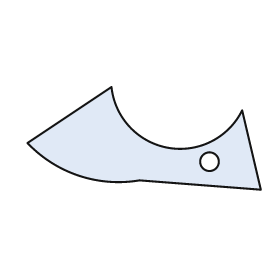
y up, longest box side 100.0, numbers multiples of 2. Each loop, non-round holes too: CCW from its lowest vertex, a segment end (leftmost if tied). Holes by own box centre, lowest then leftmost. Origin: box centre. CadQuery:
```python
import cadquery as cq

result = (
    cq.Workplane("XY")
    .moveTo(50.0, -22.0)
    .lineTo(42.0, 12.0)
    .threePointArc((10.0, -4.0), (-14.0, 22.0))
    .lineTo(-50.0, -2.0)
    .threePointArc((-28.0, -16.0), (-2.0, -18.0))
    .close()
    .moveTo(28.0, -10.0)
    .circle(4.0)
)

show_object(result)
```